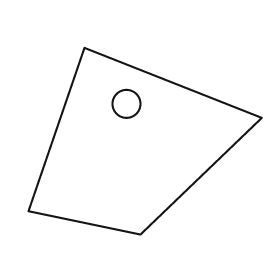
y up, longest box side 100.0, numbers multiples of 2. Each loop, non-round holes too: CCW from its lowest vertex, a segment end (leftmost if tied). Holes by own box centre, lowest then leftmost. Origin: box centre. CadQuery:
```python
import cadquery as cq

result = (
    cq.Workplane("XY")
    .moveTo(-2.0, -40.0)
    .lineTo(50.0, 10.0)
    .lineTo(-26.0, 40.0)
    .lineTo(-50.0, -30.0)
    .close()
    .moveTo(-8.0, 16.0)
    .circle(6.0)
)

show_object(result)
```